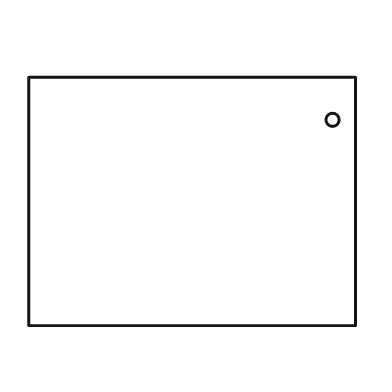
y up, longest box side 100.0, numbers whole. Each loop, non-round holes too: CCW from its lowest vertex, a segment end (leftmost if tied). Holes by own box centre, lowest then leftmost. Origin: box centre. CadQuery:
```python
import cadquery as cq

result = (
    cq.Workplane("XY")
    .moveTo(-50.0, -38.0)
    .lineTo(50.0, -38.0)
    .lineTo(50.0, 38.0)
    .lineTo(-50.0, 38.0)
    .close()
    .moveTo(43.0, 25.0)
    .circle(2.0)
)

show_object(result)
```